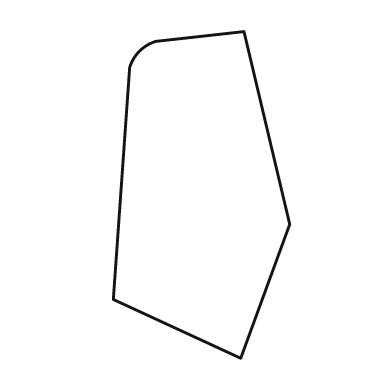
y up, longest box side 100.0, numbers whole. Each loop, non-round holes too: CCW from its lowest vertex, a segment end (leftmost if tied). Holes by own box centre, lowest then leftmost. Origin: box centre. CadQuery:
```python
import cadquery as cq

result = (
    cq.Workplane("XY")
    .moveTo(12.0, -50.0)
    .lineTo(27.0, -9.0)
    .lineTo(13.0, 50.0)
    .lineTo(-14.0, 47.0)
    .threePointArc((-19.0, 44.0), (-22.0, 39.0))
    .lineTo(-27.0, -32.0)
    .close()
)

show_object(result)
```